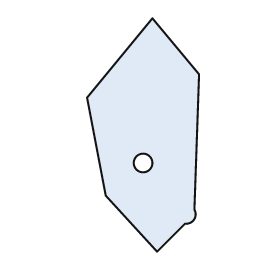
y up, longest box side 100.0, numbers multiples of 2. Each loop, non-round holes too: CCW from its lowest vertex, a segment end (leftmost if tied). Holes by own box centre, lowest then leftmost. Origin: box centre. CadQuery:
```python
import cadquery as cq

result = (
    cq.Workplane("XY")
    .moveTo(6.0, -50.0)
    .lineTo(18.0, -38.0)
    .threePointArc((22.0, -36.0), (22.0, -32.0))
    .lineTo(24.0, 26.0)
    .lineTo(4.0, 50.0)
    .lineTo(-24.0, 16.0)
    .lineTo(-16.0, -26.0)
    .close()
    .moveTo(0.0, -12.0)
    .circle(4.0)
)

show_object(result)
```